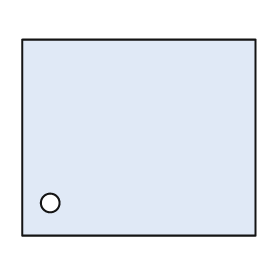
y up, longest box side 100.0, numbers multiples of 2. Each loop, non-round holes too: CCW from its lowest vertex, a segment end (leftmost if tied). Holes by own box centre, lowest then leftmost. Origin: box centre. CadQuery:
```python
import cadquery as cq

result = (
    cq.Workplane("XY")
    .moveTo(-50.0, -42.0)
    .lineTo(50.0, -42.0)
    .lineTo(50.0, 42.0)
    .lineTo(-50.0, 42.0)
    .close()
    .moveTo(-38.0, -28.0)
    .circle(4.0)
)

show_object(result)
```